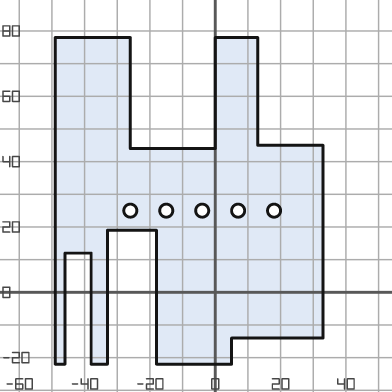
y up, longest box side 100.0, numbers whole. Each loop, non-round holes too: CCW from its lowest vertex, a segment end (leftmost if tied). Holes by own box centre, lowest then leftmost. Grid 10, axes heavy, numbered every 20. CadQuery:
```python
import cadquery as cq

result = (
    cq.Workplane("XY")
    .moveTo(-49.0, -22.0)
    .lineTo(-46.0, -22.0)
    .lineTo(-46.0, 12.0)
    .lineTo(-38.0, 12.0)
    .lineTo(-38.0, -22.0)
    .lineTo(-33.0, -22.0)
    .lineTo(-33.0, 19.0)
    .lineTo(-18.0, 19.0)
    .lineTo(-18.0, -22.0)
    .lineTo(5.0, -22.0)
    .lineTo(5.0, -14.0)
    .lineTo(33.0, -14.0)
    .lineTo(33.0, 45.0)
    .lineTo(13.0, 45.0)
    .lineTo(13.0, 78.0)
    .lineTo(0.0, 78.0)
    .lineTo(0.0, 44.0)
    .lineTo(-26.0, 44.0)
    .lineTo(-26.0, 78.0)
    .lineTo(-49.0, 78.0)
    .close()
    .moveTo(-26.0, 25.0)
    .circle(2.0)
    .moveTo(-15.0, 25.0)
    .circle(2.0)
    .moveTo(-4.0, 25.0)
    .circle(2.0)
    .moveTo(7.0, 25.0)
    .circle(2.0)
    .moveTo(18.0, 25.0)
    .circle(2.0)
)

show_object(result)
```